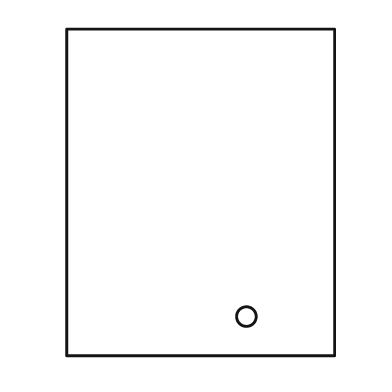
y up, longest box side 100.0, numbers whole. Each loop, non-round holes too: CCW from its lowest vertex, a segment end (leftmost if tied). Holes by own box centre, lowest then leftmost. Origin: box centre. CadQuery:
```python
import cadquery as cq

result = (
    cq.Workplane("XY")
    .moveTo(-41.0, -50.0)
    .lineTo(41.0, -50.0)
    .lineTo(41.0, 50.0)
    .lineTo(-41.0, 50.0)
    .close()
    .moveTo(14.0, -38.0)
    .circle(3.0)
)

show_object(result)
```